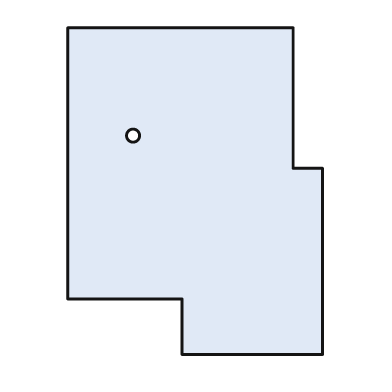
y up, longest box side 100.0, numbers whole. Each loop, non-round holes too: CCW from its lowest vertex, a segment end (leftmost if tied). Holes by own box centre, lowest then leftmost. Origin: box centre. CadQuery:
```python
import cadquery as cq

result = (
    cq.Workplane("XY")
    .moveTo(-4.0, -50.0)
    .lineTo(39.0, -50.0)
    .lineTo(39.0, 7.0)
    .lineTo(30.0, 7.0)
    .lineTo(30.0, 50.0)
    .lineTo(-39.0, 50.0)
    .lineTo(-39.0, -33.0)
    .lineTo(-4.0, -33.0)
    .close()
    .moveTo(-19.0, 17.0)
    .circle(2.0)
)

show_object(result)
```